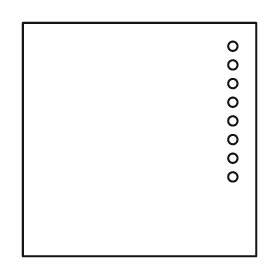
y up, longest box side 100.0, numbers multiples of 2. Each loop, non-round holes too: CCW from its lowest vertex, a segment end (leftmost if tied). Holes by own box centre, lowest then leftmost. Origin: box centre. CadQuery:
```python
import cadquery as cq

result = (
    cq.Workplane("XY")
    .moveTo(-50.0, -50.0)
    .lineTo(50.0, -50.0)
    .lineTo(50.0, 50.0)
    .lineTo(-50.0, 50.0)
    .close()
    .moveTo(40.0, -16.0)
    .circle(2.0)
    .moveTo(40.0, -8.0)
    .circle(2.0)
    .moveTo(40.0, 0.0)
    .circle(2.0)
    .moveTo(40.0, 8.0)
    .circle(2.0)
    .moveTo(40.0, 16.0)
    .circle(2.0)
    .moveTo(40.0, 24.0)
    .circle(2.0)
    .moveTo(40.0, 32.0)
    .circle(2.0)
    .moveTo(40.0, 40.0)
    .circle(2.0)
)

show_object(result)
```